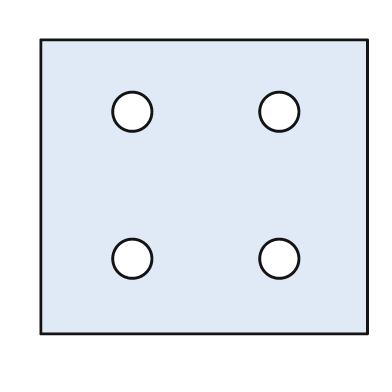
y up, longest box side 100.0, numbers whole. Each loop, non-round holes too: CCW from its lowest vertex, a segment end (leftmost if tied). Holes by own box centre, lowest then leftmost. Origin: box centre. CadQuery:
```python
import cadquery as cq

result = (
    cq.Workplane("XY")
    .moveTo(-50.0, -45.0)
    .lineTo(50.0, -45.0)
    .lineTo(50.0, 45.0)
    .lineTo(-50.0, 45.0)
    .close()
    .moveTo(-22.0, -22.0)
    .circle(6.0)
    .moveTo(23.0, -22.0)
    .circle(6.0)
    .moveTo(-22.0, 23.0)
    .circle(6.0)
    .moveTo(23.0, 23.0)
    .circle(6.0)
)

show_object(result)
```